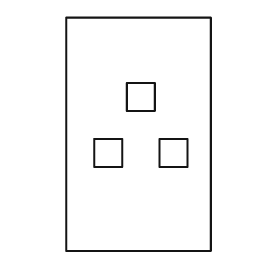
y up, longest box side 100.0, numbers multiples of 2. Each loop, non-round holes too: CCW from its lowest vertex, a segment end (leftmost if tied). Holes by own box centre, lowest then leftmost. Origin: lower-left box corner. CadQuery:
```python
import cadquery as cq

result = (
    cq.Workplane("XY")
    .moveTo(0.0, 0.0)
    .lineTo(62.0, 0.0)
    .lineTo(62.0, 100.0)
    .lineTo(0.0, 100.0)
    .close()
    .moveTo(12.0, 36.0)
    .lineTo(24.0, 36.0)
    .lineTo(24.0, 48.0)
    .lineTo(12.0, 48.0)
    .close()
    .moveTo(40.0, 36.0)
    .lineTo(52.0, 36.0)
    .lineTo(52.0, 48.0)
    .lineTo(40.0, 48.0)
    .close()
    .moveTo(26.0, 60.0)
    .lineTo(38.0, 60.0)
    .lineTo(38.0, 72.0)
    .lineTo(26.0, 72.0)
    .close()
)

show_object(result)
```